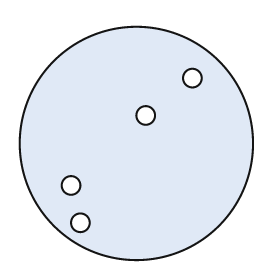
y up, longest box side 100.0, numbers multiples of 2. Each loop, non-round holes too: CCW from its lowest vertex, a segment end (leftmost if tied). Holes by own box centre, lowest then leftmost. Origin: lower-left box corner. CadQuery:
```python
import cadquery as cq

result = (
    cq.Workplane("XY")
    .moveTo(50.0, 50.0)
    .circle(50.0)
    .moveTo(26.0, 16.0)
    .circle(4.0)
    .moveTo(22.0, 32.0)
    .circle(4.0)
    .moveTo(54.0, 62.0)
    .circle(4.0)
    .moveTo(74.0, 78.0)
    .circle(4.0)
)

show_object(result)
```